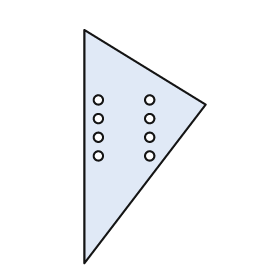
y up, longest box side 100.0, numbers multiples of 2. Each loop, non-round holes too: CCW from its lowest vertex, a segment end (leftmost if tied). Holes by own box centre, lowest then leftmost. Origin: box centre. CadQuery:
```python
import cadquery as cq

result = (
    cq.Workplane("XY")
    .moveTo(-26.0, -50.0)
    .lineTo(26.0, 18.0)
    .lineTo(-26.0, 50.0)
    .close()
    .moveTo(-20.0, -4.0)
    .circle(2.0)
    .moveTo(2.0, -4.0)
    .circle(2.0)
    .moveTo(-20.0, 4.0)
    .circle(2.0)
    .moveTo(2.0, 4.0)
    .circle(2.0)
    .moveTo(-20.0, 12.0)
    .circle(2.0)
    .moveTo(2.0, 12.0)
    .circle(2.0)
    .moveTo(-20.0, 20.0)
    .circle(2.0)
    .moveTo(2.0, 20.0)
    .circle(2.0)
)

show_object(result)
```